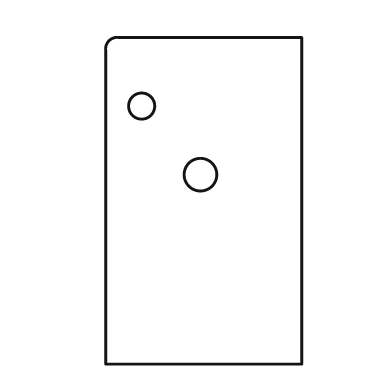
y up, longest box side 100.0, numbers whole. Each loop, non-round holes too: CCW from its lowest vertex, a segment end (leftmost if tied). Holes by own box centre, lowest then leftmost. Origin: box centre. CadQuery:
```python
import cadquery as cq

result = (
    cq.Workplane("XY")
    .moveTo(-30.0, -50.0)
    .lineTo(30.0, -50.0)
    .lineTo(30.0, 50.0)
    .lineTo(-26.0, 50.0)
    .threePointArc((-29.0, 49.0), (-30.0, 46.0))
    .close()
    .moveTo(-1.0, 8.0)
    .circle(5.0)
    .moveTo(-19.0, 29.0)
    .circle(4.0)
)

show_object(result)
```